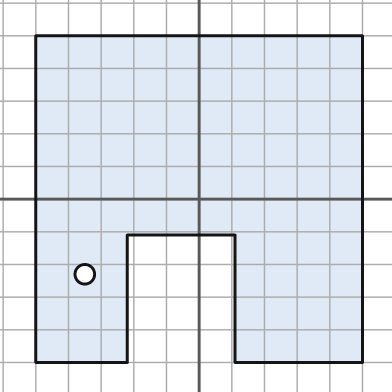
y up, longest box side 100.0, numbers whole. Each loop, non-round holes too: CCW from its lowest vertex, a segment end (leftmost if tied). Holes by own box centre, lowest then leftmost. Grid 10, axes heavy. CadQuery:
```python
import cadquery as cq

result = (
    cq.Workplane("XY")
    .moveTo(-50.0, -50.0)
    .lineTo(-22.0, -50.0)
    .lineTo(-22.0, -11.0)
    .lineTo(11.0, -11.0)
    .lineTo(11.0, -50.0)
    .lineTo(50.0, -50.0)
    .lineTo(50.0, 50.0)
    .lineTo(-50.0, 50.0)
    .close()
    .moveTo(-35.0, -23.0)
    .circle(3.0)
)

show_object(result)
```